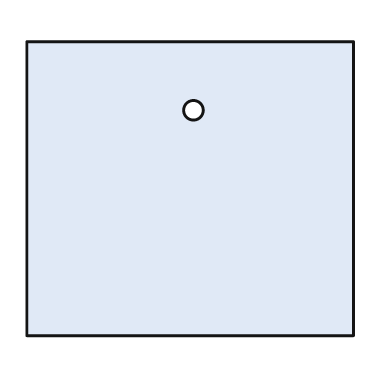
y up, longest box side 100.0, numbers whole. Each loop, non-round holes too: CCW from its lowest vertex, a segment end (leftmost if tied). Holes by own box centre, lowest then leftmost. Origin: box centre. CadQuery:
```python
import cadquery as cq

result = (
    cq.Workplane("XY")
    .moveTo(-50.0, -45.0)
    .lineTo(50.0, -45.0)
    .lineTo(50.0, 45.0)
    .lineTo(-50.0, 45.0)
    .close()
    .moveTo(1.0, 24.0)
    .circle(3.0)
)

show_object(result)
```